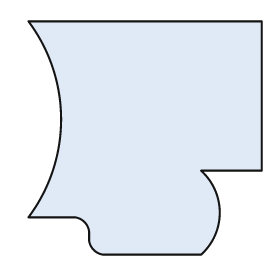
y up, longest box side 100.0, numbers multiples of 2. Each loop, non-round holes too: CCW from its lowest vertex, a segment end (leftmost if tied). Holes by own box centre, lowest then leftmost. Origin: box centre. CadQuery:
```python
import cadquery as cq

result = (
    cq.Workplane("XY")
    .moveTo(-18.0, -50.0)
    .lineTo(24.0, -50.0)
    .threePointArc((32.0, -32.0), (24.0, -14.0))
    .lineTo(50.0, -14.0)
    .lineTo(50.0, 50.0)
    .lineTo(-50.0, 50.0)
    .threePointArc((-36.0, 8.0), (-50.0, -34.0))
    .lineTo(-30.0, -34.0)
    .threePointArc((-26.0, -36.0), (-24.0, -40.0))
    .lineTo(-24.0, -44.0)
    .threePointArc((-22.0, -48.0), (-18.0, -50.0))
    .close()
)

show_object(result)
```